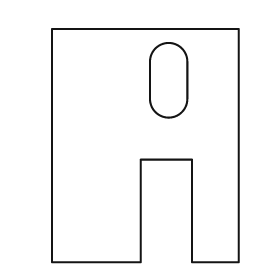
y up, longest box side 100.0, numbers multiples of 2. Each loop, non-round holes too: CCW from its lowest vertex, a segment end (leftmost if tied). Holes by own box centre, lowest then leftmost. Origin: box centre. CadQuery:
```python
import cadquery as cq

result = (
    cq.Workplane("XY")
    .moveTo(-40.0, -50.0)
    .lineTo(-2.0, -50.0)
    .lineTo(-2.0, -6.0)
    .lineTo(20.0, -6.0)
    .lineTo(20.0, -50.0)
    .lineTo(40.0, -50.0)
    .lineTo(40.0, 50.0)
    .lineTo(-40.0, 50.0)
    .close()
    .moveTo(2.0, 20.0)
    .threePointArc((10.0, 12.0), (18.0, 20.0))
    .lineTo(18.0, 36.0)
    .threePointArc((10.0, 44.0), (2.0, 36.0))
    .close()
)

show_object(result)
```